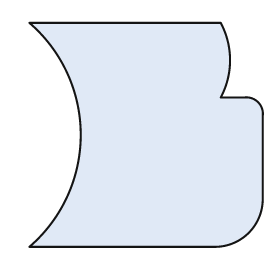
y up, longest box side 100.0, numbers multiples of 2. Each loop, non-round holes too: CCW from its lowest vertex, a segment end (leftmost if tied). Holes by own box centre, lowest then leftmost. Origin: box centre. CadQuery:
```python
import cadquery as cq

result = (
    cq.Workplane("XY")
    .moveTo(-50.0, -48.0)
    .lineTo(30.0, -48.0)
    .threePointArc((44.0, -42.0), (50.0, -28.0))
    .lineTo(50.0, 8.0)
    .threePointArc((48.0, 14.0), (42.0, 16.0))
    .lineTo(32.0, 16.0)
    .threePointArc((36.0, 32.0), (32.0, 48.0))
    .lineTo(-50.0, 48.0)
    .threePointArc((-28.0, 0.0), (-50.0, -48.0))
    .close()
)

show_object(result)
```